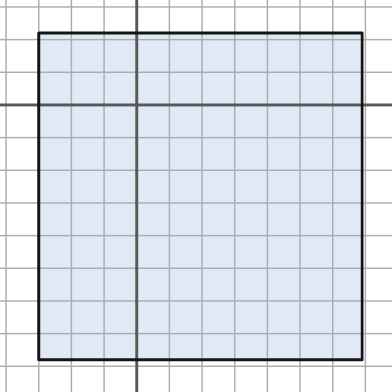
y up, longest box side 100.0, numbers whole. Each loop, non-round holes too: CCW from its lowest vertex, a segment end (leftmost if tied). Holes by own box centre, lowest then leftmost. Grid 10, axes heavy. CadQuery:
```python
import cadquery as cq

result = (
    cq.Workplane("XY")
    .moveTo(-30.0, -78.0)
    .lineTo(69.0, -78.0)
    .lineTo(69.0, 22.0)
    .lineTo(-30.0, 22.0)
    .close()
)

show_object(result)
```